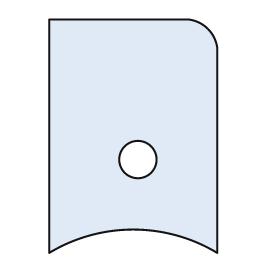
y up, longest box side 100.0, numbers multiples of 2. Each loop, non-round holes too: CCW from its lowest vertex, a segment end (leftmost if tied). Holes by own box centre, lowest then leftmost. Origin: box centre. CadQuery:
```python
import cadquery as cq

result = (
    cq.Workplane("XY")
    .moveTo(-36.0, -50.0)
    .threePointArc((0.0, -40.0), (36.0, -50.0))
    .lineTo(36.0, 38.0)
    .threePointArc((32.0, 46.0), (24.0, 50.0))
    .lineTo(-36.0, 50.0)
    .close()
    .moveTo(2.0, -10.0)
    .circle(8.0)
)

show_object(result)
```